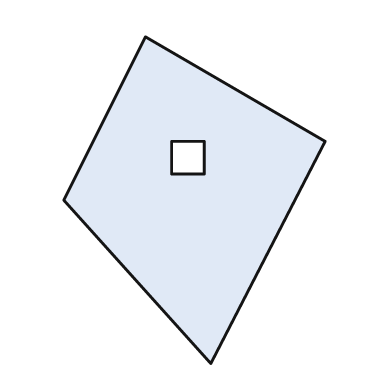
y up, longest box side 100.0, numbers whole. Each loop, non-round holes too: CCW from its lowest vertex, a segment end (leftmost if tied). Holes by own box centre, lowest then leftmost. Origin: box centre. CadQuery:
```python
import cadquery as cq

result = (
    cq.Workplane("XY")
    .moveTo(5.0, -50.0)
    .lineTo(40.0, 18.0)
    .lineTo(-15.0, 50.0)
    .lineTo(-40.0, 0.0)
    .close()
    .moveTo(-7.0, 8.0)
    .lineTo(3.0, 8.0)
    .lineTo(3.0, 18.0)
    .lineTo(-7.0, 18.0)
    .close()
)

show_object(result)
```